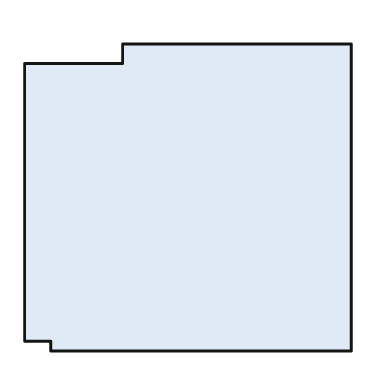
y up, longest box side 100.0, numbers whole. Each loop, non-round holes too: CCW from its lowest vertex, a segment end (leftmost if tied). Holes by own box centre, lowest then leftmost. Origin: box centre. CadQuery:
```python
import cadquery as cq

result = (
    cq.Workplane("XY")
    .moveTo(-42.0, -47.0)
    .lineTo(50.0, -47.0)
    .lineTo(50.0, 47.0)
    .lineTo(-20.0, 47.0)
    .lineTo(-20.0, 41.0)
    .lineTo(-50.0, 41.0)
    .lineTo(-50.0, -44.0)
    .lineTo(-42.0, -44.0)
    .close()
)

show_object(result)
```